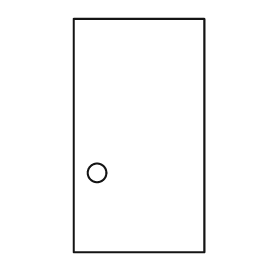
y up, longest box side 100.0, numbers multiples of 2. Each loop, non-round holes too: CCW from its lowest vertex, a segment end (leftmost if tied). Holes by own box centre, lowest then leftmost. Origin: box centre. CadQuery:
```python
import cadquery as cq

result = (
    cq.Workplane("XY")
    .moveTo(-28.0, -50.0)
    .lineTo(28.0, -50.0)
    .lineTo(28.0, 50.0)
    .lineTo(-28.0, 50.0)
    .close()
    .moveTo(-18.0, -16.0)
    .circle(4.0)
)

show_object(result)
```